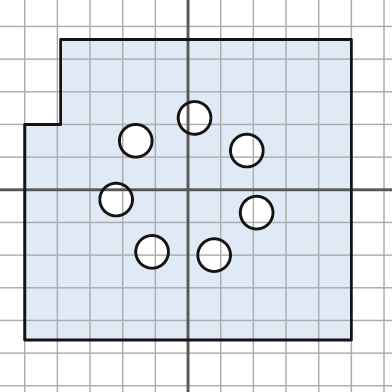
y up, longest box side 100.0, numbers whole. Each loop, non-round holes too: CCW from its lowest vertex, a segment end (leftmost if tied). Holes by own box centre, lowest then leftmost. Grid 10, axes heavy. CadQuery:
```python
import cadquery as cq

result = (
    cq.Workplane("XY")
    .moveTo(-50.0, -46.0)
    .lineTo(50.0, -46.0)
    .lineTo(50.0, 46.0)
    .lineTo(-39.0, 46.0)
    .lineTo(-39.0, 20.0)
    .lineTo(-50.0, 20.0)
    .close()
    .moveTo(8.0, -20.0)
    .circle(5.0)
    .moveTo(-11.0, -19.0)
    .circle(5.0)
    .moveTo(21.0, -7.0)
    .circle(5.0)
    .moveTo(-22.0, -3.0)
    .circle(5.0)
    .moveTo(18.0, 12.0)
    .circle(5.0)
    .moveTo(-16.0, 15.0)
    .circle(5.0)
    .moveTo(2.0, 22.0)
    .circle(5.0)
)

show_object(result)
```